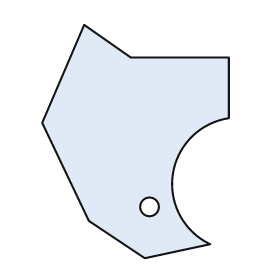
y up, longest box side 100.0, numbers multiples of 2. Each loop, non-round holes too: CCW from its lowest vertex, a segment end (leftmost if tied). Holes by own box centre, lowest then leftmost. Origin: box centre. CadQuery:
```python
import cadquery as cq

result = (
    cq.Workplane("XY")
    .moveTo(4.0, -50.0)
    .lineTo(32.0, -44.0)
    .threePointArc((16.0, -14.0), (40.0, 10.0))
    .lineTo(40.0, 36.0)
    .lineTo(-2.0, 36.0)
    .lineTo(-22.0, 50.0)
    .lineTo(-40.0, 8.0)
    .lineTo(-20.0, -34.0)
    .close()
    .moveTo(6.0, -28.0)
    .circle(4.0)
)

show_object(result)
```